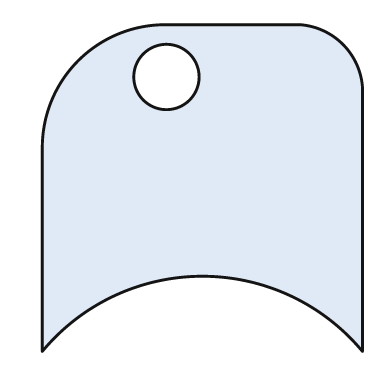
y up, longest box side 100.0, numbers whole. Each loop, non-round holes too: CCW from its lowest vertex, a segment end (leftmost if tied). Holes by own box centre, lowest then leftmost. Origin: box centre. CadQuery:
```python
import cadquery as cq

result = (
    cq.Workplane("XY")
    .moveTo(-49.0, -50.0)
    .threePointArc((0.0, -27.0), (49.0, -50.0))
    .lineTo(49.0, 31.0)
    .threePointArc((43.0, 44.0), (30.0, 50.0))
    .lineTo(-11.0, 50.0)
    .threePointArc((-38.0, 39.0), (-49.0, 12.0))
    .close()
    .moveTo(-11.0, 34.0)
    .circle(10.0)
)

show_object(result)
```